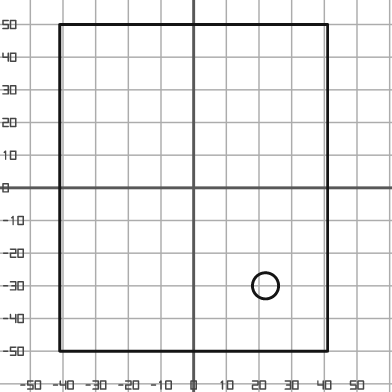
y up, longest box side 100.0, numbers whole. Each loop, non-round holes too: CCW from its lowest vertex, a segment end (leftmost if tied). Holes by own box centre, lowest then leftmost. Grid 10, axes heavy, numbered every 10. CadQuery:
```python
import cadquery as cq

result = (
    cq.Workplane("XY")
    .moveTo(-41.0, -50.0)
    .lineTo(41.0, -50.0)
    .lineTo(41.0, 50.0)
    .lineTo(-41.0, 50.0)
    .close()
    .moveTo(22.0, -30.0)
    .circle(4.0)
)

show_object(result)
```